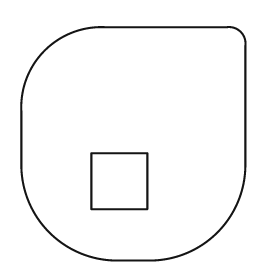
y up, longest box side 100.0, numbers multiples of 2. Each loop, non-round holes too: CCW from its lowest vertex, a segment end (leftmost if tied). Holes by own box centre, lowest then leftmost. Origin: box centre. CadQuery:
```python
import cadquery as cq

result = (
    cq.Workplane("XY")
    .moveTo(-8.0, -50.0)
    .lineTo(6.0, -50.0)
    .threePointArc((36.0, -38.0), (48.0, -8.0))
    .lineTo(48.0, 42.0)
    .threePointArc((46.0, 48.0), (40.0, 50.0))
    .lineTo(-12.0, 50.0)
    .threePointArc((-38.0, 40.0), (-48.0, 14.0))
    .lineTo(-48.0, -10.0)
    .threePointArc((-36.0, -38.0), (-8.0, -50.0))
    .close()
    .moveTo(-18.0, -28.0)
    .lineTo(6.0, -28.0)
    .lineTo(6.0, -4.0)
    .lineTo(-18.0, -4.0)
    .close()
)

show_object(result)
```